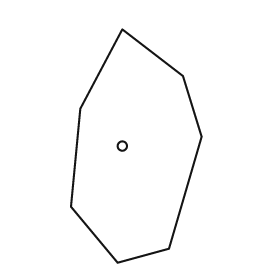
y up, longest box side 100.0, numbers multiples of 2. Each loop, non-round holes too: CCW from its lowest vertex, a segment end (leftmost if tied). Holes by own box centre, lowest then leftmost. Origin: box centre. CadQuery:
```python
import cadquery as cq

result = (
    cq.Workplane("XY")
    .moveTo(-8.0, -50.0)
    .lineTo(14.0, -44.0)
    .lineTo(28.0, 4.0)
    .lineTo(20.0, 30.0)
    .lineTo(-6.0, 50.0)
    .lineTo(-24.0, 16.0)
    .lineTo(-28.0, -26.0)
    .close()
    .moveTo(-6.0, 0.0)
    .circle(2.0)
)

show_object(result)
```